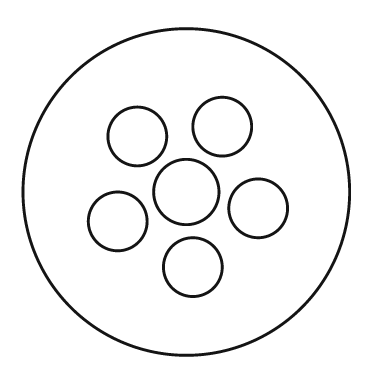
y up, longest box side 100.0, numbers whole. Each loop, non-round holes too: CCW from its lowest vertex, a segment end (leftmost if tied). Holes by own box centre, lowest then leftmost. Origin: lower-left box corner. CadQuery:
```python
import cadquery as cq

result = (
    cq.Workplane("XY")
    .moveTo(50.0, 50.0)
    .circle(50.0)
    .moveTo(52.0, 27.0)
    .circle(9.0)
    .moveTo(29.0, 41.0)
    .circle(9.0)
    .moveTo(72.0, 45.0)
    .circle(9.0)
    .moveTo(50.0, 50.0)
    .circle(10.0)
    .moveTo(35.0, 67.0)
    .circle(9.0)
    .moveTo(61.0, 70.0)
    .circle(9.0)
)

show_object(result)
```